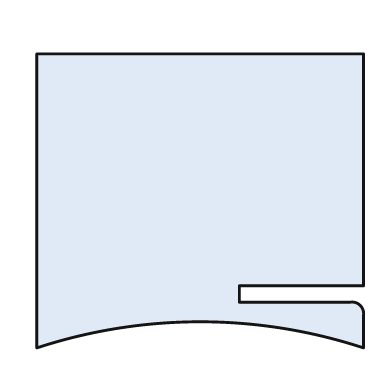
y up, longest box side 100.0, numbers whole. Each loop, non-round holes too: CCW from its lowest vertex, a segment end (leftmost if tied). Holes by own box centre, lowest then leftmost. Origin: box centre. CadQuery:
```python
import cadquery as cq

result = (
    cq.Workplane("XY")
    .moveTo(-50.0, -45.0)
    .threePointArc((0.0, -37.0), (50.0, -45.0))
    .lineTo(50.0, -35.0)
    .threePointArc((49.0, -32.0), (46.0, -31.0))
    .lineTo(12.0, -31.0)
    .lineTo(12.0, -26.0)
    .lineTo(50.0, -26.0)
    .lineTo(50.0, 45.0)
    .lineTo(-50.0, 45.0)
    .close()
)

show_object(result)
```